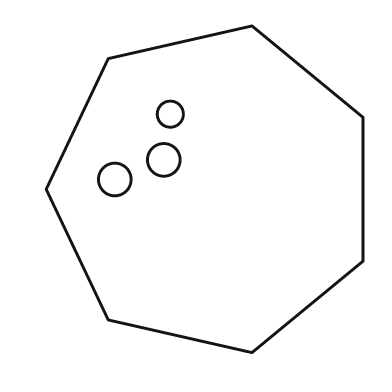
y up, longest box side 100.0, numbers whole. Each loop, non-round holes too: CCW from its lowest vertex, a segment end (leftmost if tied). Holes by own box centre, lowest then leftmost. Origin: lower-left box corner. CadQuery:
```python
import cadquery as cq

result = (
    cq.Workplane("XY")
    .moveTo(63.0, 0.0)
    .lineTo(97.0, 28.0)
    .lineTo(97.0, 72.0)
    .lineTo(63.0, 100.0)
    .lineTo(19.0, 90.0)
    .lineTo(0.0, 50.0)
    .lineTo(19.0, 10.0)
    .close()
    .moveTo(21.0, 53.0)
    .circle(5.0)
    .moveTo(36.0, 59.0)
    .circle(5.0)
    .moveTo(38.0, 73.0)
    .circle(4.0)
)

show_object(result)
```